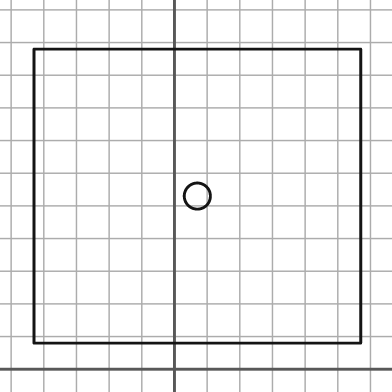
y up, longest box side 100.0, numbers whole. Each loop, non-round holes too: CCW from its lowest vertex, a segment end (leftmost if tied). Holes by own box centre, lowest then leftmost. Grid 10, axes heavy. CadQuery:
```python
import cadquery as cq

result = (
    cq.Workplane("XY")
    .moveTo(-43.0, 8.0)
    .lineTo(57.0, 8.0)
    .lineTo(57.0, 98.0)
    .lineTo(-43.0, 98.0)
    .close()
    .moveTo(7.0, 53.0)
    .circle(4.0)
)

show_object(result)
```